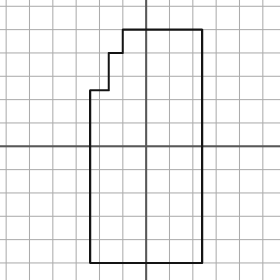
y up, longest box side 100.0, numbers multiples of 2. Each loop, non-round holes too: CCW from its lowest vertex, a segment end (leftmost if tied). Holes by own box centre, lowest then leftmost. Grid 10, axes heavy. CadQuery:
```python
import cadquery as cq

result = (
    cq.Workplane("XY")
    .moveTo(-24.0, -50.0)
    .lineTo(24.0, -50.0)
    .lineTo(24.0, 50.0)
    .lineTo(-10.0, 50.0)
    .lineTo(-10.0, 40.0)
    .lineTo(-16.0, 40.0)
    .lineTo(-16.0, 24.0)
    .lineTo(-24.0, 24.0)
    .close()
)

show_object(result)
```